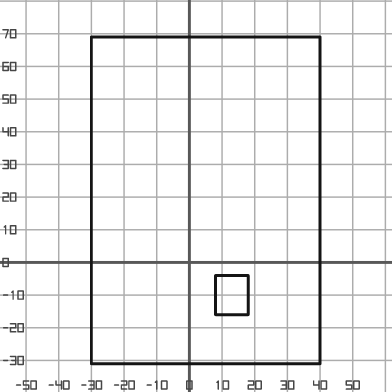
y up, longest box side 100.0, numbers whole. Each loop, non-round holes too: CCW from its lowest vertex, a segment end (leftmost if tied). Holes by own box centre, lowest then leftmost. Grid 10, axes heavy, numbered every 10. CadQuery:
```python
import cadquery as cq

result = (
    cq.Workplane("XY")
    .moveTo(-30.0, -31.0)
    .lineTo(40.0, -31.0)
    .lineTo(40.0, 69.0)
    .lineTo(-30.0, 69.0)
    .close()
    .moveTo(8.0, -16.0)
    .lineTo(18.0, -16.0)
    .lineTo(18.0, -4.0)
    .lineTo(8.0, -4.0)
    .close()
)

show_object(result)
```